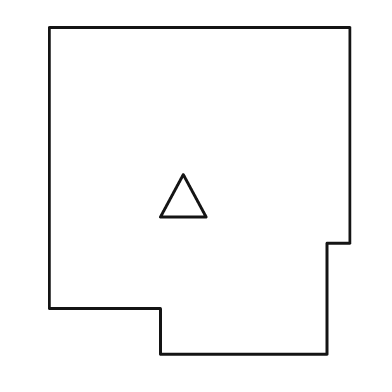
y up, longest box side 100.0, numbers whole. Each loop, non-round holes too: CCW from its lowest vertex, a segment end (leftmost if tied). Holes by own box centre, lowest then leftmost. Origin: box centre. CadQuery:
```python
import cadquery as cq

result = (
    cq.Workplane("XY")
    .moveTo(-12.0, -50.0)
    .lineTo(39.0, -50.0)
    .lineTo(39.0, -16.0)
    .lineTo(46.0, -16.0)
    .lineTo(46.0, 50.0)
    .lineTo(-46.0, 50.0)
    .lineTo(-46.0, -36.0)
    .lineTo(-12.0, -36.0)
    .close()
    .moveTo(-12.0, -8.0)
    .lineTo(2.0, -8.0)
    .lineTo(-5.0, 5.0)
    .close()
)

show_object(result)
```